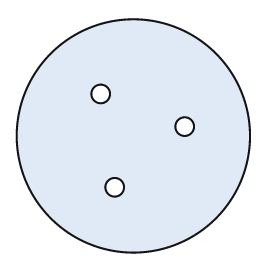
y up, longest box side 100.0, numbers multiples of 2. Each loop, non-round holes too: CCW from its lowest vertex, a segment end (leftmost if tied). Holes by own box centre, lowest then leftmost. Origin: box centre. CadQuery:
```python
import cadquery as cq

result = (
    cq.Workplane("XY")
    .moveTo(0.0, 0.0)
    .circle(50.0)
    .moveTo(-8.0, -22.0)
    .circle(4.0)
    .moveTo(22.0, 4.0)
    .circle(4.0)
    .moveTo(-14.0, 18.0)
    .circle(4.0)
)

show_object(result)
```